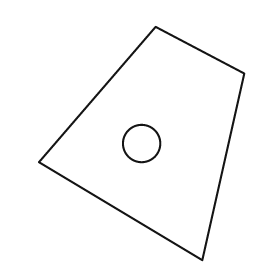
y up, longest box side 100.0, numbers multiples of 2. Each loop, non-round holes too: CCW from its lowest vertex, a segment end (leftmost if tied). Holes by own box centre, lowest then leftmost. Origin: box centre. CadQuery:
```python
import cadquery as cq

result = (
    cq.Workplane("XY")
    .moveTo(26.0, -50.0)
    .lineTo(44.0, 30.0)
    .lineTo(6.0, 50.0)
    .lineTo(-44.0, -8.0)
    .close()
    .moveTo(0.0, 0.0)
    .circle(8.0)
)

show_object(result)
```